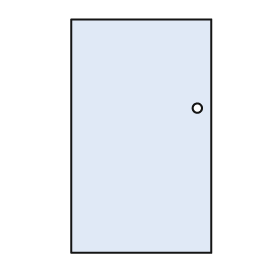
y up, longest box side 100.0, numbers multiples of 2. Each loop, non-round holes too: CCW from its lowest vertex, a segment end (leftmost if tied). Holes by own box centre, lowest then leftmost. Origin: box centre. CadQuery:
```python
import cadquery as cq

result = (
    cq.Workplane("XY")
    .moveTo(-30.0, -50.0)
    .lineTo(30.0, -50.0)
    .lineTo(30.0, 50.0)
    .lineTo(-30.0, 50.0)
    .close()
    .moveTo(24.0, 12.0)
    .circle(2.0)
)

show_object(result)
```